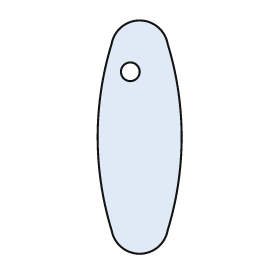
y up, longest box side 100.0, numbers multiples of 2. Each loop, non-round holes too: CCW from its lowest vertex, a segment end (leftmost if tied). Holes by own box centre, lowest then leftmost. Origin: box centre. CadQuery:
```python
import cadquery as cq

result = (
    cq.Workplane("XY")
    .moveTo(-12.0, -40.0)
    .threePointArc((0.0, -50.0), (12.0, -40.0))
    .threePointArc((18.0, 0.0), (12.0, 40.0))
    .threePointArc((0.0, 50.0), (-12.0, 40.0))
    .threePointArc((-18.0, 0.0), (-12.0, -40.0))
    .close()
    .moveTo(-4.0, 28.0)
    .circle(4.0)
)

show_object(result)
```